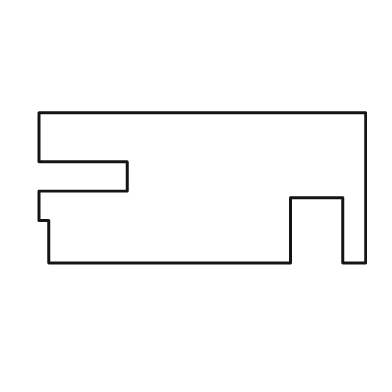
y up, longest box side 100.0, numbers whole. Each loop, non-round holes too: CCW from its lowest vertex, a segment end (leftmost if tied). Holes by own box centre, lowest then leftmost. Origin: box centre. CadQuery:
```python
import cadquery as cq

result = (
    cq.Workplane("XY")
    .moveTo(-47.0, -23.0)
    .lineTo(27.0, -23.0)
    .lineTo(27.0, -3.0)
    .lineTo(43.0, -3.0)
    .lineTo(43.0, -23.0)
    .lineTo(50.0, -23.0)
    .lineTo(50.0, 23.0)
    .lineTo(-50.0, 23.0)
    .lineTo(-50.0, 8.0)
    .lineTo(-23.0, 8.0)
    .lineTo(-23.0, -1.0)
    .lineTo(-50.0, -1.0)
    .lineTo(-50.0, -10.0)
    .lineTo(-47.0, -10.0)
    .close()
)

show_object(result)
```